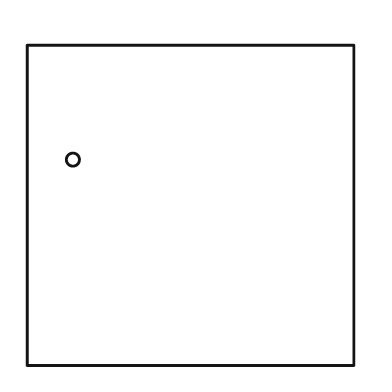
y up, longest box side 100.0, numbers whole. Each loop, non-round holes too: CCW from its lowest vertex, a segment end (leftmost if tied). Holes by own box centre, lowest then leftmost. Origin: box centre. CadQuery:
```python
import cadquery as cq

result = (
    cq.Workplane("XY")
    .moveTo(-50.0, -49.0)
    .lineTo(50.0, -49.0)
    .lineTo(50.0, 49.0)
    .lineTo(-50.0, 49.0)
    .close()
    .moveTo(-36.0, 14.0)
    .circle(2.0)
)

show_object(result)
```